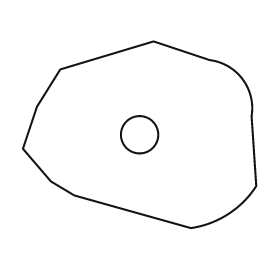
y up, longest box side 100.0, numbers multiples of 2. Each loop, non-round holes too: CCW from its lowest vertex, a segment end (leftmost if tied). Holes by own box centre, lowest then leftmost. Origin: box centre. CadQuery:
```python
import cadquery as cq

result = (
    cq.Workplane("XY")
    .moveTo(22.0, -40.0)
    .threePointArc((38.0, -34.0), (50.0, -22.0))
    .lineTo(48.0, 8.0)
    .threePointArc((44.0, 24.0), (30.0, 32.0))
    .lineTo(6.0, 40.0)
    .lineTo(-34.0, 28.0)
    .lineTo(-44.0, 12.0)
    .lineTo(-50.0, -6.0)
    .lineTo(-38.0, -20.0)
    .lineTo(-28.0, -26.0)
    .close()
    .moveTo(0.0, 0.0)
    .circle(8.0)
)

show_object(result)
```